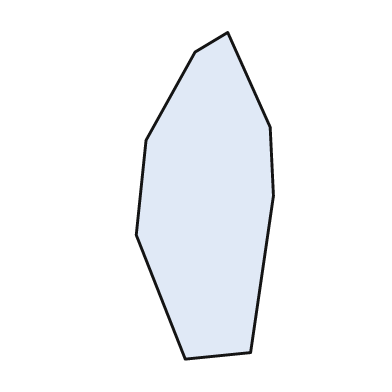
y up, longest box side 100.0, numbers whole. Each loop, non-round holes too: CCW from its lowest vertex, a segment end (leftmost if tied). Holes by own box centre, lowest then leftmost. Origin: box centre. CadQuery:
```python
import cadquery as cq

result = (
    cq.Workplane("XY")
    .moveTo(-6.0, -50.0)
    .lineTo(14.0, -48.0)
    .lineTo(21.0, 0.0)
    .lineTo(20.0, 21.0)
    .lineTo(7.0, 50.0)
    .lineTo(-3.0, 44.0)
    .lineTo(-18.0, 17.0)
    .lineTo(-21.0, -12.0)
    .close()
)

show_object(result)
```